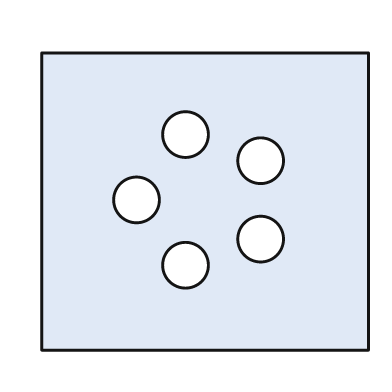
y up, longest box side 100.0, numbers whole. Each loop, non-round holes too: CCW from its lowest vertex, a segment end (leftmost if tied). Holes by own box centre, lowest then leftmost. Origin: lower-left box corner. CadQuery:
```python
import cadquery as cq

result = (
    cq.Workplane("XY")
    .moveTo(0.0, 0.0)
    .lineTo(100.0, 0.0)
    .lineTo(100.0, 91.0)
    .lineTo(0.0, 91.0)
    .close()
    .moveTo(44.0, 26.0)
    .circle(7.0)
    .moveTo(67.0, 34.0)
    .circle(7.0)
    .moveTo(29.0, 46.0)
    .circle(7.0)
    .moveTo(67.0, 58.0)
    .circle(7.0)
    .moveTo(44.0, 66.0)
    .circle(7.0)
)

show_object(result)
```